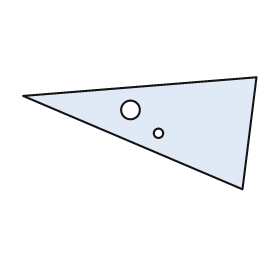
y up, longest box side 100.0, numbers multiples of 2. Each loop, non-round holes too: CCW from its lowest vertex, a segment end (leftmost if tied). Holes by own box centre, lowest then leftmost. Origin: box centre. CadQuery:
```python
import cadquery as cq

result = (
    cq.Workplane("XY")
    .moveTo(44.0, -24.0)
    .lineTo(50.0, 24.0)
    .lineTo(-50.0, 16.0)
    .close()
    .moveTo(8.0, 0.0)
    .circle(2.0)
    .moveTo(-4.0, 10.0)
    .circle(4.0)
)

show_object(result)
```